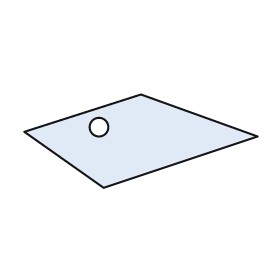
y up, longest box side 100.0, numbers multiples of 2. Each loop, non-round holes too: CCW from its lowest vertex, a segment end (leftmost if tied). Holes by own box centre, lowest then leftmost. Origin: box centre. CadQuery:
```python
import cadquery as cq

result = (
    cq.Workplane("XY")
    .moveTo(-16.0, -20.0)
    .lineTo(50.0, 2.0)
    .lineTo(0.0, 20.0)
    .lineTo(-50.0, 4.0)
    .close()
    .moveTo(-18.0, 6.0)
    .circle(4.0)
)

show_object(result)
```